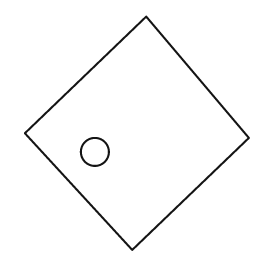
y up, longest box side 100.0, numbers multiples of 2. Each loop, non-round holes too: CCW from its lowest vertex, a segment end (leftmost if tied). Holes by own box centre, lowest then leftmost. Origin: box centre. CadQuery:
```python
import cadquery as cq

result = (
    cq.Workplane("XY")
    .moveTo(-2.0, -50.0)
    .lineTo(48.0, -2.0)
    .lineTo(4.0, 50.0)
    .lineTo(-48.0, 0.0)
    .close()
    .moveTo(-18.0, -8.0)
    .circle(6.0)
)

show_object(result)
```